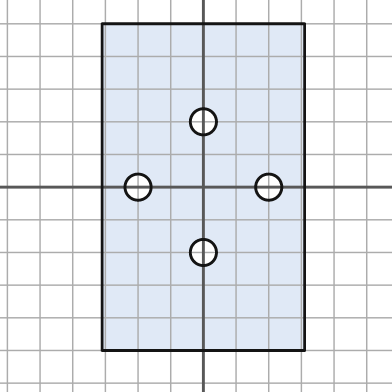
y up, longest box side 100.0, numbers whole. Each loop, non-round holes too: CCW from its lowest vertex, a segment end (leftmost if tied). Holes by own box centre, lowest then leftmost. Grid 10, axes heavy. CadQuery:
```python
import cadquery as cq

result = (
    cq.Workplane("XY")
    .moveTo(-31.0, -50.0)
    .lineTo(31.0, -50.0)
    .lineTo(31.0, 50.0)
    .lineTo(-31.0, 50.0)
    .close()
    .moveTo(0.0, -20.0)
    .circle(4.0)
    .moveTo(-20.0, 0.0)
    .circle(4.0)
    .moveTo(20.0, 0.0)
    .circle(4.0)
    .moveTo(0.0, 20.0)
    .circle(4.0)
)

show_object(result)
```